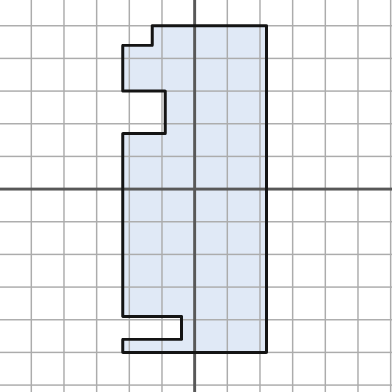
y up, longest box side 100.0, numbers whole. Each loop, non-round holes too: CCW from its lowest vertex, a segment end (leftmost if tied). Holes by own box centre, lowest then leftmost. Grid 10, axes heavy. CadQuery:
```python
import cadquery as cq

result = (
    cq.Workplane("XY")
    .moveTo(-22.0, -50.0)
    .lineTo(22.0, -50.0)
    .lineTo(22.0, 50.0)
    .lineTo(-13.0, 50.0)
    .lineTo(-13.0, 44.0)
    .lineTo(-22.0, 44.0)
    .lineTo(-22.0, 30.0)
    .lineTo(-9.0, 30.0)
    .lineTo(-9.0, 17.0)
    .lineTo(-22.0, 17.0)
    .lineTo(-22.0, -39.0)
    .lineTo(-4.0, -39.0)
    .lineTo(-4.0, -46.0)
    .lineTo(-22.0, -46.0)
    .close()
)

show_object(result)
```